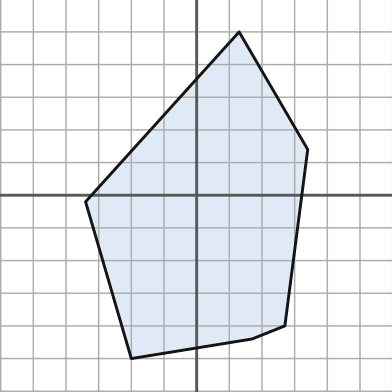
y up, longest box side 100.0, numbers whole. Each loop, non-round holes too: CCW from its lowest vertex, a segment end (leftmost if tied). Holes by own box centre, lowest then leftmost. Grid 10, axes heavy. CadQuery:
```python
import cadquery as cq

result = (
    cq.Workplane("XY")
    .moveTo(-20.0, -50.0)
    .lineTo(17.0, -44.0)
    .lineTo(27.0, -40.0)
    .lineTo(34.0, 14.0)
    .lineTo(13.0, 50.0)
    .lineTo(-34.0, -2.0)
    .close()
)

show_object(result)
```